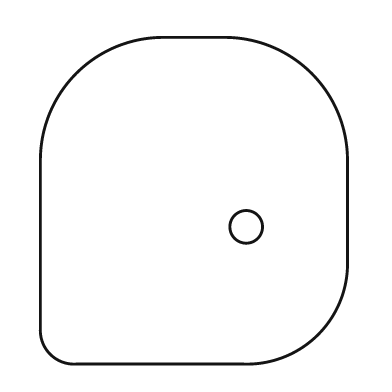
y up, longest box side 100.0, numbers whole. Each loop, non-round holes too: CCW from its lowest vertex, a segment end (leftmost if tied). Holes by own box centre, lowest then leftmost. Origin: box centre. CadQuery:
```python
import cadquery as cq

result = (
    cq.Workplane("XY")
    .moveTo(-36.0, -50.0)
    .lineTo(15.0, -50.0)
    .threePointArc((38.0, -41.0), (47.0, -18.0))
    .lineTo(47.0, 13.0)
    .threePointArc((36.0, 39.0), (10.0, 50.0))
    .lineTo(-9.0, 50.0)
    .threePointArc((-36.0, 39.0), (-47.0, 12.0))
    .lineTo(-47.0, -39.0)
    .threePointArc((-44.0, -47.0), (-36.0, -50.0))
    .close()
    .moveTo(16.0, -8.0)
    .circle(5.0)
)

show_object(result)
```